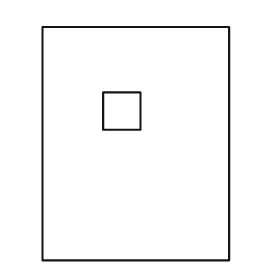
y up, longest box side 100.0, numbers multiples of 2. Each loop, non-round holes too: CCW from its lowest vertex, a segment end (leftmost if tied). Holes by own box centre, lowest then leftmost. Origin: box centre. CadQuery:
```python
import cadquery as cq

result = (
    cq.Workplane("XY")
    .moveTo(-40.0, -50.0)
    .lineTo(40.0, -50.0)
    .lineTo(40.0, 50.0)
    .lineTo(-40.0, 50.0)
    .close()
    .moveTo(-14.0, 6.0)
    .lineTo(2.0, 6.0)
    .lineTo(2.0, 22.0)
    .lineTo(-14.0, 22.0)
    .close()
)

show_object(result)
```